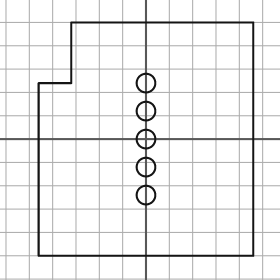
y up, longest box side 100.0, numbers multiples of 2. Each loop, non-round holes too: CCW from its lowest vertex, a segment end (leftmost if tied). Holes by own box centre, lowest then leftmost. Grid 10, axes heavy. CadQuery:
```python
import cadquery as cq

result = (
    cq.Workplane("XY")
    .moveTo(-46.0, -50.0)
    .lineTo(46.0, -50.0)
    .lineTo(46.0, 50.0)
    .lineTo(-32.0, 50.0)
    .lineTo(-32.0, 24.0)
    .lineTo(-46.0, 24.0)
    .close()
    .moveTo(0.0, -24.0)
    .circle(4.0)
    .moveTo(0.0, -12.0)
    .circle(4.0)
    .moveTo(0.0, 0.0)
    .circle(4.0)
    .moveTo(0.0, 12.0)
    .circle(4.0)
    .moveTo(0.0, 24.0)
    .circle(4.0)
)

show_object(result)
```